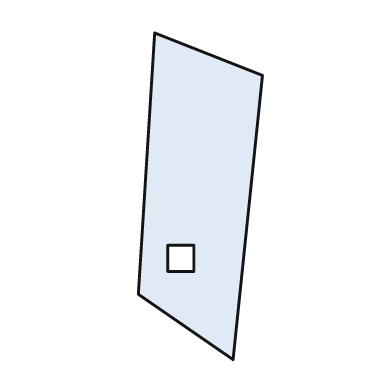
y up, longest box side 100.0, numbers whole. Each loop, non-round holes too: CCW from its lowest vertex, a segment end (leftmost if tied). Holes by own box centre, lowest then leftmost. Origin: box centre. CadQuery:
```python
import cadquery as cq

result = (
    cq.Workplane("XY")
    .moveTo(10.0, -50.0)
    .lineTo(19.0, 37.0)
    .lineTo(-14.0, 50.0)
    .lineTo(-19.0, -30.0)
    .close()
    .moveTo(-10.0, -23.0)
    .lineTo(-2.0, -23.0)
    .lineTo(-2.0, -15.0)
    .lineTo(-10.0, -15.0)
    .close()
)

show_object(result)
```